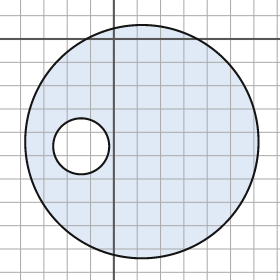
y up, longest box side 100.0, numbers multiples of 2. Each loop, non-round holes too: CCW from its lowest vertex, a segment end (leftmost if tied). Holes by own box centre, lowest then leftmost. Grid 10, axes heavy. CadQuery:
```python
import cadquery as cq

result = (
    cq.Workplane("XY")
    .moveTo(12.0, -44.0)
    .circle(50.0)
    .moveTo(-14.0, -46.0)
    .circle(12.0)
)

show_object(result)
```